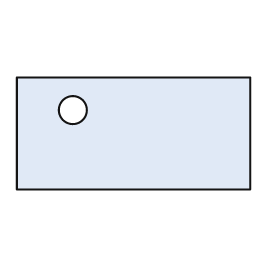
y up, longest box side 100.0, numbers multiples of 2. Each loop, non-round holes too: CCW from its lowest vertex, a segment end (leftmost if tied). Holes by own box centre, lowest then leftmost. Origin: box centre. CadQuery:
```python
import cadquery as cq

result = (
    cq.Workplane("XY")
    .moveTo(-50.0, -24.0)
    .lineTo(50.0, -24.0)
    .lineTo(50.0, 24.0)
    .lineTo(-50.0, 24.0)
    .close()
    .moveTo(-26.0, 10.0)
    .circle(6.0)
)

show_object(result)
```